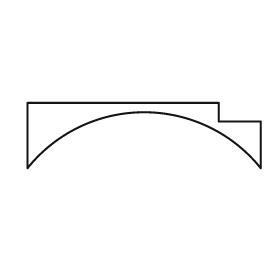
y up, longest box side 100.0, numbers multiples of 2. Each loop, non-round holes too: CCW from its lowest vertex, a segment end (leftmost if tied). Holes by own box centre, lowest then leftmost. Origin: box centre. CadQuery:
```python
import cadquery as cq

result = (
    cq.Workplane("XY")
    .moveTo(-50.0, -14.0)
    .threePointArc((0.0, 10.0), (50.0, -14.0))
    .lineTo(50.0, 6.0)
    .lineTo(32.0, 6.0)
    .lineTo(32.0, 14.0)
    .lineTo(-50.0, 14.0)
    .close()
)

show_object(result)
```